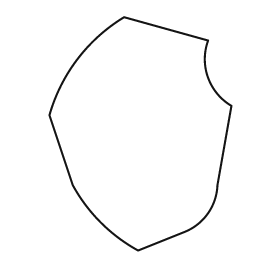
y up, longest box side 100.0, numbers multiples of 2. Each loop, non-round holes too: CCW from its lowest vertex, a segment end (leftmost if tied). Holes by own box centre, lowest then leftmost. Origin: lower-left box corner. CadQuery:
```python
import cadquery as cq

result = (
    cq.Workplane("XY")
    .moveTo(38.0, 0.0)
    .lineTo(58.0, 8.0)
    .threePointArc((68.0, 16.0), (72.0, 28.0))
    .lineTo(78.0, 62.0)
    .threePointArc((68.0, 74.0), (68.0, 90.0))
    .lineTo(32.0, 100.0)
    .threePointArc((12.0, 82.0), (0.0, 58.0))
    .lineTo(10.0, 28.0)
    .threePointArc((22.0, 12.0), (38.0, 0.0))
    .close()
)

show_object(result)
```